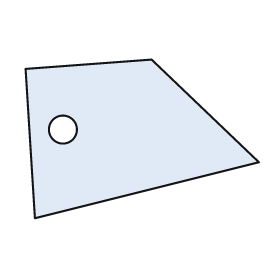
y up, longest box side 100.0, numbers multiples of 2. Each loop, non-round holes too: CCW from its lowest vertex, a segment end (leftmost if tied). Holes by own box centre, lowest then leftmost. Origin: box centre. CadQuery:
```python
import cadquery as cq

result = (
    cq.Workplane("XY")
    .moveTo(-46.0, -34.0)
    .lineTo(50.0, -10.0)
    .lineTo(4.0, 34.0)
    .lineTo(-50.0, 30.0)
    .close()
    .moveTo(-34.0, 4.0)
    .circle(6.0)
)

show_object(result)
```